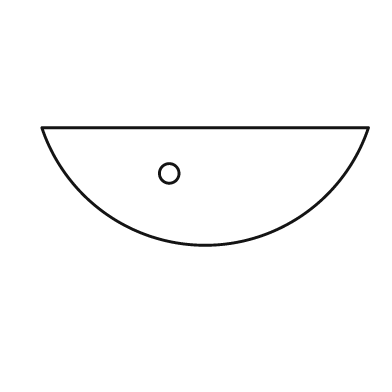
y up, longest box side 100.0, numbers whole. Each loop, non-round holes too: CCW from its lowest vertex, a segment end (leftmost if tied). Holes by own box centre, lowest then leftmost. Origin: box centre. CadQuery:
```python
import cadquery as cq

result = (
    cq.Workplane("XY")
    .moveTo(-50.0, 18.0)
    .threePointArc((0.0, -18.0), (50.0, 18.0))
    .close()
    .moveTo(-11.0, 4.0)
    .circle(3.0)
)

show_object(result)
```